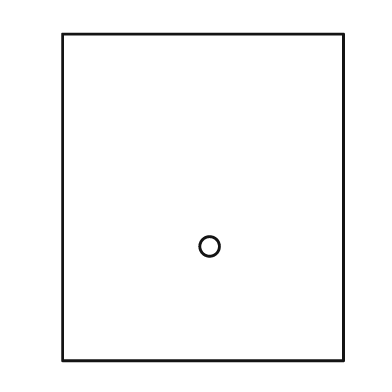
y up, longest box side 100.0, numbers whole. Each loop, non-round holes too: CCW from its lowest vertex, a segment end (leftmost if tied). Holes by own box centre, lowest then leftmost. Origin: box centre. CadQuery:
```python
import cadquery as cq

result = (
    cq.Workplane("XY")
    .moveTo(-43.0, -50.0)
    .lineTo(43.0, -50.0)
    .lineTo(43.0, 50.0)
    .lineTo(-43.0, 50.0)
    .close()
    .moveTo(2.0, -15.0)
    .circle(3.0)
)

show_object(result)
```